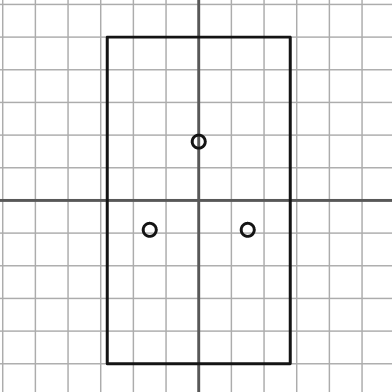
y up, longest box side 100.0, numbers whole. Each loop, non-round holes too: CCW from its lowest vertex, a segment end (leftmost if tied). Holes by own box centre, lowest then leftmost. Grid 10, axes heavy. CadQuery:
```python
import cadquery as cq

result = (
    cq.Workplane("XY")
    .moveTo(-28.0, -50.0)
    .lineTo(28.0, -50.0)
    .lineTo(28.0, 50.0)
    .lineTo(-28.0, 50.0)
    .close()
    .moveTo(-15.0, -9.0)
    .circle(2.0)
    .moveTo(15.0, -9.0)
    .circle(2.0)
    .moveTo(0.0, 18.0)
    .circle(2.0)
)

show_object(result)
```